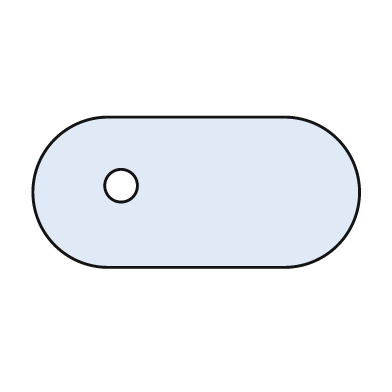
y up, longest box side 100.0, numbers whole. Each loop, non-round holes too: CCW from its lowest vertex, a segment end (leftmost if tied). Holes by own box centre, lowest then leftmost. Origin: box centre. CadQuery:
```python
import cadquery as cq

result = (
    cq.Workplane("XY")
    .moveTo(-27.0, -23.0)
    .lineTo(27.0, -23.0)
    .threePointArc((50.0, 0.0), (27.0, 23.0))
    .lineTo(-27.0, 23.0)
    .threePointArc((-50.0, 0.0), (-27.0, -23.0))
    .close()
    .moveTo(-23.0, 2.0)
    .circle(5.0)
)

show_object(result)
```